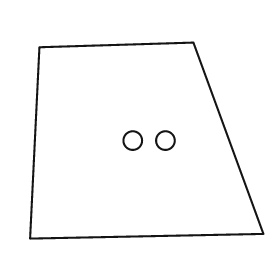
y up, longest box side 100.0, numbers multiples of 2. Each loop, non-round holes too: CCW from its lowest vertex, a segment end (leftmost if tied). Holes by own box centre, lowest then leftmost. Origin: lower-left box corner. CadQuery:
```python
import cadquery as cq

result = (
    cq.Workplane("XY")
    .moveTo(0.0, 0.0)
    .lineTo(100.0, 2.0)
    .lineTo(70.0, 84.0)
    .lineTo(4.0, 82.0)
    .close()
    .moveTo(44.0, 42.0)
    .circle(4.0)
    .moveTo(58.0, 42.0)
    .circle(4.0)
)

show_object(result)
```